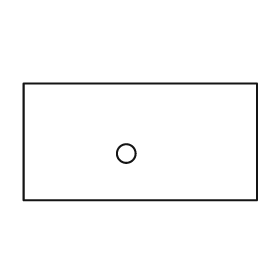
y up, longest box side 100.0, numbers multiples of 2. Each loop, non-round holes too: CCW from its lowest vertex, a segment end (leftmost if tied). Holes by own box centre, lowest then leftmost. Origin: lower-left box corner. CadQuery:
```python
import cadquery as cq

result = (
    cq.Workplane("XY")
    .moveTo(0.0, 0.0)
    .lineTo(100.0, 0.0)
    .lineTo(100.0, 50.0)
    .lineTo(0.0, 50.0)
    .close()
    .moveTo(44.0, 20.0)
    .circle(4.0)
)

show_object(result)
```